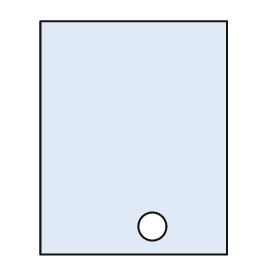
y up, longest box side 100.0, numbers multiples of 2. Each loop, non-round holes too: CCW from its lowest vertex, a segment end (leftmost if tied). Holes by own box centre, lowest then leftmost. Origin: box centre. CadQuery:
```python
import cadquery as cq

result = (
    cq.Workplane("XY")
    .moveTo(-40.0, -50.0)
    .lineTo(40.0, -50.0)
    .lineTo(40.0, 50.0)
    .lineTo(-40.0, 50.0)
    .close()
    .moveTo(8.0, -38.0)
    .circle(6.0)
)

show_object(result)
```